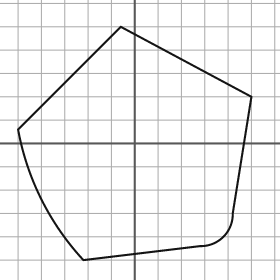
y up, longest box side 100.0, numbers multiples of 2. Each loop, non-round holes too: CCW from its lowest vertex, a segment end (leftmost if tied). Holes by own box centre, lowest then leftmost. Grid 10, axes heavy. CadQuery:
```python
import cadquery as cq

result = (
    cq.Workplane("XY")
    .moveTo(-22.0, -50.0)
    .lineTo(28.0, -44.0)
    .threePointArc((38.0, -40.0), (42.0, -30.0))
    .lineTo(50.0, 20.0)
    .lineTo(-6.0, 50.0)
    .lineTo(-50.0, 6.0)
    .threePointArc((-40.0, -24.0), (-22.0, -50.0))
    .close()
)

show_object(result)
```